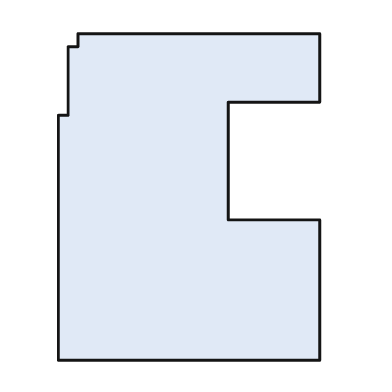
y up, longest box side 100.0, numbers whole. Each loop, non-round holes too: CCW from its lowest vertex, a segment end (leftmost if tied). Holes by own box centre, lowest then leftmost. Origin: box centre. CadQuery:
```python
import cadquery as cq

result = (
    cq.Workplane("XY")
    .moveTo(-40.0, -50.0)
    .lineTo(40.0, -50.0)
    .lineTo(40.0, -7.0)
    .lineTo(12.0, -7.0)
    .lineTo(12.0, 29.0)
    .lineTo(40.0, 29.0)
    .lineTo(40.0, 50.0)
    .lineTo(-34.0, 50.0)
    .lineTo(-34.0, 46.0)
    .lineTo(-37.0, 46.0)
    .lineTo(-37.0, 25.0)
    .lineTo(-40.0, 25.0)
    .close()
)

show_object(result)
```